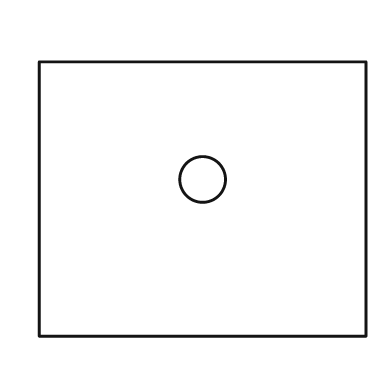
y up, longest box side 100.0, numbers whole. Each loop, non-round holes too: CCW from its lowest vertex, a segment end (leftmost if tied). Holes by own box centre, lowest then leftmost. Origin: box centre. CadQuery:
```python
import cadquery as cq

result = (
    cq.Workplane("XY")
    .moveTo(-50.0, -42.0)
    .lineTo(50.0, -42.0)
    .lineTo(50.0, 42.0)
    .lineTo(-50.0, 42.0)
    .close()
    .moveTo(0.0, 6.0)
    .circle(7.0)
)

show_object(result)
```